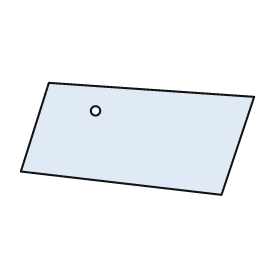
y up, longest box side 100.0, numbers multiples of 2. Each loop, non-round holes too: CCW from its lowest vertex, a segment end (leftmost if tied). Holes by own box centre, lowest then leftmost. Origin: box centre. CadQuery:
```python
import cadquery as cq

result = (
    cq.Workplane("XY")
    .moveTo(36.0, -24.0)
    .lineTo(50.0, 18.0)
    .lineTo(-38.0, 24.0)
    .lineTo(-50.0, -14.0)
    .close()
    .moveTo(-18.0, 12.0)
    .circle(2.0)
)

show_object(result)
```